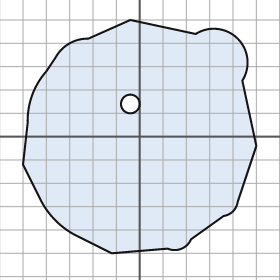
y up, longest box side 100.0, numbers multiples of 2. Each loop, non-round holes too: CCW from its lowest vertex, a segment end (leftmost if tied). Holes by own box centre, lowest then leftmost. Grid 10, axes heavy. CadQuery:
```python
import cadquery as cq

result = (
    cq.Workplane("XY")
    .moveTo(-12.0, -50.0)
    .lineTo(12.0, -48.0)
    .threePointArc((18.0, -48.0), (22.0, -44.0))
    .lineTo(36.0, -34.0)
    .threePointArc((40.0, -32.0), (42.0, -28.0))
    .lineTo(50.0, -4.0)
    .lineTo(44.0, 24.0)
    .threePointArc((42.0, 42.0), (24.0, 44.0))
    .lineTo(-4.0, 50.0)
    .lineTo(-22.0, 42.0)
    .threePointArc((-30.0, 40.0), (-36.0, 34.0))
    .lineTo(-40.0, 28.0)
    .threePointArc((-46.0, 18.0), (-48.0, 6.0))
    .lineTo(-50.0, -12.0)
    .lineTo(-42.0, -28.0)
    .threePointArc((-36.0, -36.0), (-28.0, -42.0))
    .close()
    .moveTo(-4.0, 14.0)
    .circle(4.0)
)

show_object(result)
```